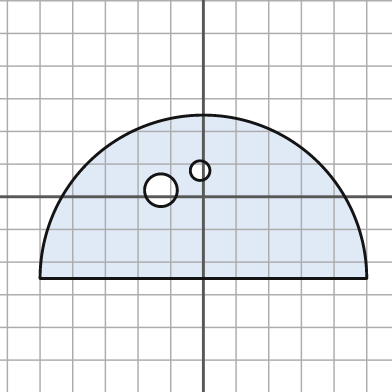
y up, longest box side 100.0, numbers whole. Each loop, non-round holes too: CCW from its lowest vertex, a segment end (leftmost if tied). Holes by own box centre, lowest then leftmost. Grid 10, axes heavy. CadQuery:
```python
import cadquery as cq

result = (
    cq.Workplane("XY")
    .moveTo(-50.0, -25.0)
    .lineTo(50.0, -25.0)
    .threePointArc((0.0, 25.0), (-50.0, -25.0))
    .close()
    .moveTo(-13.0, 2.0)
    .circle(5.0)
    .moveTo(-1.0, 8.0)
    .circle(3.0)
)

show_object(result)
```